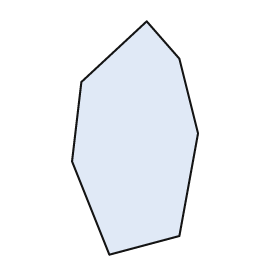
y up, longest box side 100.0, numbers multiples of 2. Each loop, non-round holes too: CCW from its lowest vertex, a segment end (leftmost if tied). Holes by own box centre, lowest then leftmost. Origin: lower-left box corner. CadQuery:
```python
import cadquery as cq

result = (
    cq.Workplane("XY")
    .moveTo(16.0, 0.0)
    .lineTo(46.0, 8.0)
    .lineTo(54.0, 52.0)
    .lineTo(46.0, 84.0)
    .lineTo(32.0, 100.0)
    .lineTo(4.0, 74.0)
    .lineTo(0.0, 40.0)
    .close()
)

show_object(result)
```